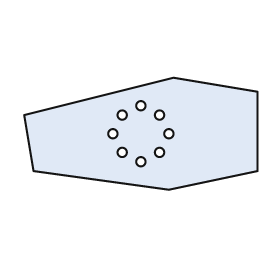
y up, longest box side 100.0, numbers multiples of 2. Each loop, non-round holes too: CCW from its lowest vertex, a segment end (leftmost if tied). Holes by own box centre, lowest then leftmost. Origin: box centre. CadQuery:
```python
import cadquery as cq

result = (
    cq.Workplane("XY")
    .moveTo(12.0, -24.0)
    .lineTo(50.0, -16.0)
    .lineTo(50.0, 18.0)
    .lineTo(14.0, 24.0)
    .lineTo(-50.0, 8.0)
    .lineTo(-46.0, -16.0)
    .close()
    .moveTo(0.0, -12.0)
    .circle(2.0)
    .moveTo(-8.0, -8.0)
    .circle(2.0)
    .moveTo(8.0, -8.0)
    .circle(2.0)
    .moveTo(-12.0, 0.0)
    .circle(2.0)
    .moveTo(12.0, 0.0)
    .circle(2.0)
    .moveTo(-8.0, 8.0)
    .circle(2.0)
    .moveTo(8.0, 8.0)
    .circle(2.0)
    .moveTo(0.0, 12.0)
    .circle(2.0)
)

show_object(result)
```